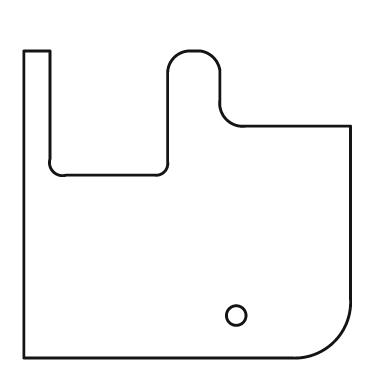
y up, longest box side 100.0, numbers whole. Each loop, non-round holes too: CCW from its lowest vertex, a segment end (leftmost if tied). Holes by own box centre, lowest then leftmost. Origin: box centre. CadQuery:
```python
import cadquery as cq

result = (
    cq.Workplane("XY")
    .moveTo(-50.0, -47.0)
    .lineTo(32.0, -47.0)
    .threePointArc((45.0, -42.0), (50.0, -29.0))
    .lineTo(50.0, 24.0)
    .lineTo(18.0, 24.0)
    .threePointArc((12.0, 26.0), (10.0, 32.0))
    .lineTo(10.0, 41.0)
    .threePointArc((8.0, 45.0), (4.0, 47.0))
    .lineTo(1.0, 47.0)
    .threePointArc((-4.0, 45.0), (-6.0, 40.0))
    .lineTo(-6.0, 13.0)
    .threePointArc((-7.0, 10.0), (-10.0, 9.0))
    .lineTo(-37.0, 9.0)
    .threePointArc((-41.0, 10.0), (-42.0, 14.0))
    .lineTo(-42.0, 47.0)
    .lineTo(-50.0, 47.0)
    .close()
    .moveTo(15.0, -34.0)
    .circle(3.0)
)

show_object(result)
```